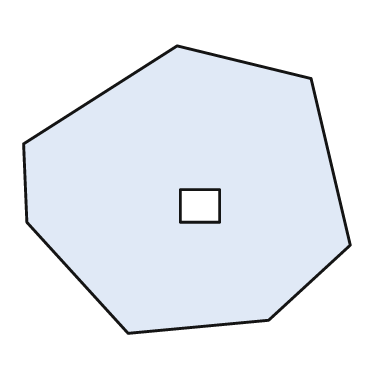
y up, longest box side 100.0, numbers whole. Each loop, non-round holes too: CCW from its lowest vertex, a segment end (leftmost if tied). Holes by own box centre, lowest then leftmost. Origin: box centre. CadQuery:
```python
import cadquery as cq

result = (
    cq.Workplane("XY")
    .moveTo(-18.0, -44.0)
    .lineTo(25.0, -40.0)
    .lineTo(50.0, -17.0)
    .lineTo(38.0, 34.0)
    .lineTo(-3.0, 44.0)
    .lineTo(-50.0, 14.0)
    .lineTo(-49.0, -10.0)
    .close()
    .moveTo(-2.0, -10.0)
    .lineTo(10.0, -10.0)
    .lineTo(10.0, 0.0)
    .lineTo(-2.0, 0.0)
    .close()
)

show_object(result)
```